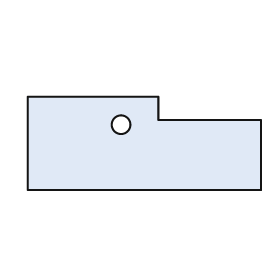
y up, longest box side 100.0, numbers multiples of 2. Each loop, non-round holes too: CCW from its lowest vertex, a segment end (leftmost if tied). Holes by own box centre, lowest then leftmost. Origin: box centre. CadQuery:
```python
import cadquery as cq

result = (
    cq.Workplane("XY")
    .moveTo(-50.0, -20.0)
    .lineTo(50.0, -20.0)
    .lineTo(50.0, 10.0)
    .lineTo(6.0, 10.0)
    .lineTo(6.0, 20.0)
    .lineTo(-50.0, 20.0)
    .close()
    .moveTo(-10.0, 8.0)
    .circle(4.0)
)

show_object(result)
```